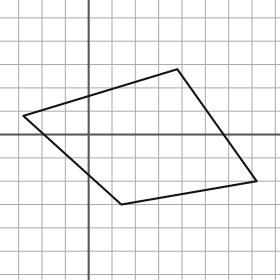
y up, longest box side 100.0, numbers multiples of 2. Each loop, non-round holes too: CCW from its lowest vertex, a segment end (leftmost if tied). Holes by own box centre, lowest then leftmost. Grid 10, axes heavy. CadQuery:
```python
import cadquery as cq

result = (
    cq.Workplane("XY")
    .moveTo(14.0, -30.0)
    .lineTo(72.0, -20.0)
    .lineTo(38.0, 28.0)
    .lineTo(-28.0, 8.0)
    .close()
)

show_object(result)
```